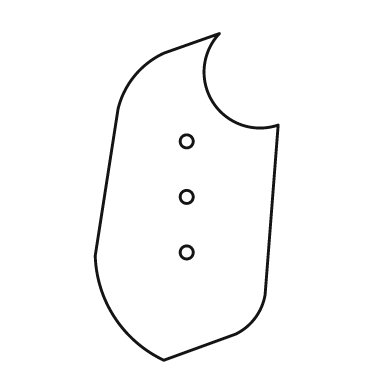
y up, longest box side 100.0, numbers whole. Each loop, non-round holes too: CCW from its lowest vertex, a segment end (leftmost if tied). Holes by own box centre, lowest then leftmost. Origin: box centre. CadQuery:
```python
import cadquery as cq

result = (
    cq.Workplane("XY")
    .moveTo(-7.0, -50.0)
    .lineTo(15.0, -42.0)
    .threePointArc((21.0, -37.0), (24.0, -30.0))
    .lineTo(28.0, 22.0)
    .threePointArc((8.0, 29.0), (10.0, 50.0))
    .lineTo(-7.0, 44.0)
    .threePointArc((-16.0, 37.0), (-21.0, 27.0))
    .lineTo(-28.0, -18.0)
    .threePointArc((-22.0, -37.0), (-7.0, -50.0))
    .close()
    .moveTo(0.0, -17.0)
    .circle(2.0)
    .moveTo(0.0, 0.0)
    .circle(2.0)
    .moveTo(0.0, 17.0)
    .circle(2.0)
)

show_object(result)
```